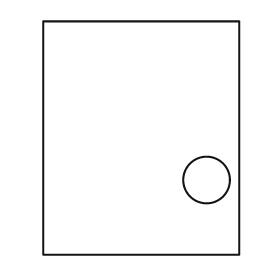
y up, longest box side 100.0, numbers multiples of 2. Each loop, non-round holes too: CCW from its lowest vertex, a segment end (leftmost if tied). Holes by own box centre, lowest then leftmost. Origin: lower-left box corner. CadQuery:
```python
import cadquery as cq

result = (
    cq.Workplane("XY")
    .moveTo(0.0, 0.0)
    .lineTo(84.0, 0.0)
    .lineTo(84.0, 100.0)
    .lineTo(0.0, 100.0)
    .close()
    .moveTo(70.0, 32.0)
    .circle(10.0)
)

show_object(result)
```